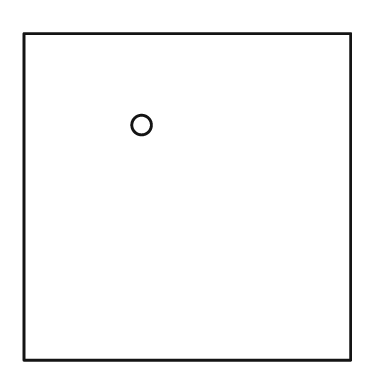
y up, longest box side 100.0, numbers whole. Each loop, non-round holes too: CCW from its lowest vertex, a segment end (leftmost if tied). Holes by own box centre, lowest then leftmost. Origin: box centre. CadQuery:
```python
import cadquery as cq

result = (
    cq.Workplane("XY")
    .moveTo(-50.0, -50.0)
    .lineTo(50.0, -50.0)
    .lineTo(50.0, 50.0)
    .lineTo(-50.0, 50.0)
    .close()
    .moveTo(-14.0, 22.0)
    .circle(3.0)
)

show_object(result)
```